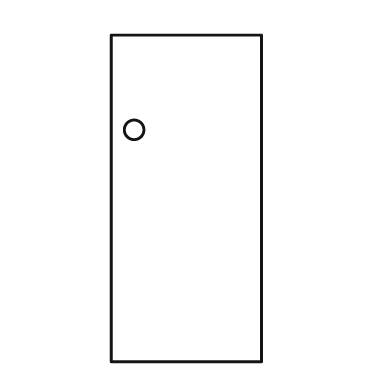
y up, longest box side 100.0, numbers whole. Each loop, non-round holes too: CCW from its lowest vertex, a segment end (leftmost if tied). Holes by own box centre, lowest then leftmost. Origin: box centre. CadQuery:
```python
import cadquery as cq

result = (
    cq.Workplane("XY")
    .moveTo(-23.0, -50.0)
    .lineTo(23.0, -50.0)
    .lineTo(23.0, 50.0)
    .lineTo(-23.0, 50.0)
    .close()
    .moveTo(-16.0, 21.0)
    .circle(3.0)
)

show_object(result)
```